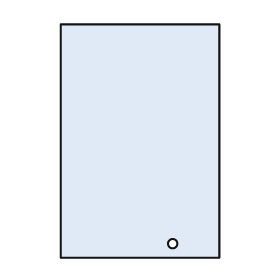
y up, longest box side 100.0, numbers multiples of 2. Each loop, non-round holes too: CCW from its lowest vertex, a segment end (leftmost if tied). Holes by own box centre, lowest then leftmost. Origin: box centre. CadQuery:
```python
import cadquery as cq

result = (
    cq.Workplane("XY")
    .moveTo(-34.0, -50.0)
    .lineTo(34.0, -50.0)
    .lineTo(34.0, 50.0)
    .lineTo(-34.0, 50.0)
    .close()
    .moveTo(14.0, -44.0)
    .circle(2.0)
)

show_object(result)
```